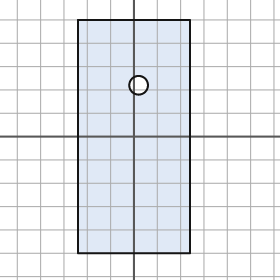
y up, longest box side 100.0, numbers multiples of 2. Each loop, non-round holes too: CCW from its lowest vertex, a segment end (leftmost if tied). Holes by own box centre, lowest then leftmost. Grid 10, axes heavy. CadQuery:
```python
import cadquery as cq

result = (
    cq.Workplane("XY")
    .moveTo(-24.0, -50.0)
    .lineTo(24.0, -50.0)
    .lineTo(24.0, 50.0)
    .lineTo(-24.0, 50.0)
    .close()
    .moveTo(2.0, 22.0)
    .circle(4.0)
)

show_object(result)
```